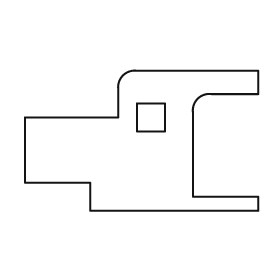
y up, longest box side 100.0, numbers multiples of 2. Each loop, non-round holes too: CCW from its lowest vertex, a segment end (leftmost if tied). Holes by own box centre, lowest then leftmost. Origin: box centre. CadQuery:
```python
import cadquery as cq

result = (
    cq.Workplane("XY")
    .moveTo(-22.0, -30.0)
    .lineTo(50.0, -30.0)
    .lineTo(50.0, -24.0)
    .lineTo(22.0, -24.0)
    .lineTo(22.0, 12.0)
    .threePointArc((24.0, 18.0), (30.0, 20.0))
    .lineTo(50.0, 20.0)
    .lineTo(50.0, 30.0)
    .lineTo(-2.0, 30.0)
    .threePointArc((-8.0, 28.0), (-10.0, 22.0))
    .lineTo(-10.0, 10.0)
    .lineTo(-50.0, 10.0)
    .lineTo(-50.0, -18.0)
    .lineTo(-22.0, -18.0)
    .close()
    .moveTo(-2.0, 4.0)
    .lineTo(10.0, 4.0)
    .lineTo(10.0, 16.0)
    .lineTo(-2.0, 16.0)
    .close()
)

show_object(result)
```